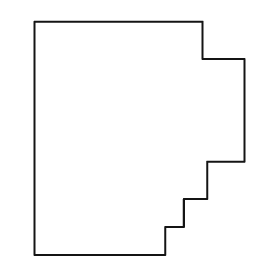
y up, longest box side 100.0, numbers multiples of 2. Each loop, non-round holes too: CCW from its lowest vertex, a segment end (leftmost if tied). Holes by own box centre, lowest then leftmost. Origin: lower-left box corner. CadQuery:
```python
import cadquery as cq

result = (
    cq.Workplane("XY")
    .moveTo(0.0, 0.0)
    .lineTo(56.0, 0.0)
    .lineTo(56.0, 12.0)
    .lineTo(64.0, 12.0)
    .lineTo(64.0, 24.0)
    .lineTo(74.0, 24.0)
    .lineTo(74.0, 40.0)
    .lineTo(90.0, 40.0)
    .lineTo(90.0, 84.0)
    .lineTo(72.0, 84.0)
    .lineTo(72.0, 100.0)
    .lineTo(0.0, 100.0)
    .close()
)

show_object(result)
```